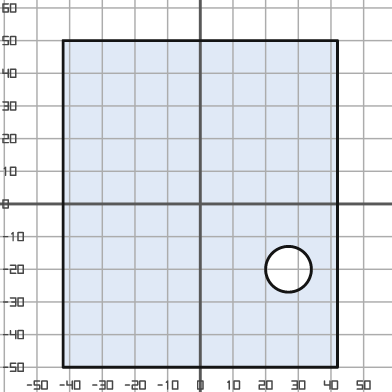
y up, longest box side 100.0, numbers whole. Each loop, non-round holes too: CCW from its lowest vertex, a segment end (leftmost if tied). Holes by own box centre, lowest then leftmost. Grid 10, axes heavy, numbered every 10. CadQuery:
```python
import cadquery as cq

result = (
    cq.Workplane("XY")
    .moveTo(-42.0, -50.0)
    .lineTo(42.0, -50.0)
    .lineTo(42.0, 50.0)
    .lineTo(-42.0, 50.0)
    .close()
    .moveTo(27.0, -20.0)
    .circle(7.0)
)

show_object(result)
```